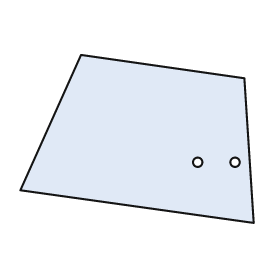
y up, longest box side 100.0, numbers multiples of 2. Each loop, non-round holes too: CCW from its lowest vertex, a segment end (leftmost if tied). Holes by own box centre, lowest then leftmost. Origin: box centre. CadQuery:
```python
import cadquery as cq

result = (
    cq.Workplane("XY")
    .moveTo(50.0, -36.0)
    .lineTo(46.0, 26.0)
    .lineTo(-24.0, 36.0)
    .lineTo(-50.0, -22.0)
    .close()
    .moveTo(26.0, -10.0)
    .circle(2.0)
    .moveTo(42.0, -10.0)
    .circle(2.0)
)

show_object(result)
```